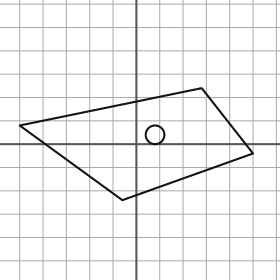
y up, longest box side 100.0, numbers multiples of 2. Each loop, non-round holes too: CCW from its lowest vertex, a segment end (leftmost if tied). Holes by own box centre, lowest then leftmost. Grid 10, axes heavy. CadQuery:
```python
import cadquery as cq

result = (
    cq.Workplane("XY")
    .moveTo(-6.0, -24.0)
    .lineTo(50.0, -4.0)
    .lineTo(28.0, 24.0)
    .lineTo(-50.0, 8.0)
    .close()
    .moveTo(8.0, 4.0)
    .circle(4.0)
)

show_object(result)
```